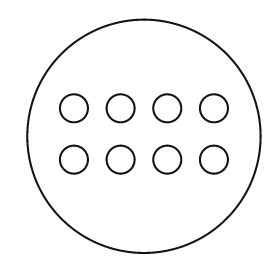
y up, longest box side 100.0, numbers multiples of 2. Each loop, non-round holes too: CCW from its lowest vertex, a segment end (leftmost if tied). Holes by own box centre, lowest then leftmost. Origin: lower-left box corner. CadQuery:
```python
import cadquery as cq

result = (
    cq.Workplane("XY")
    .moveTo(50.0, 50.0)
    .circle(50.0)
    .moveTo(20.0, 40.0)
    .circle(6.0)
    .moveTo(40.0, 40.0)
    .circle(6.0)
    .moveTo(60.0, 40.0)
    .circle(6.0)
    .moveTo(80.0, 40.0)
    .circle(6.0)
    .moveTo(20.0, 62.0)
    .circle(6.0)
    .moveTo(40.0, 62.0)
    .circle(6.0)
    .moveTo(60.0, 62.0)
    .circle(6.0)
    .moveTo(80.0, 62.0)
    .circle(6.0)
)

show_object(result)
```